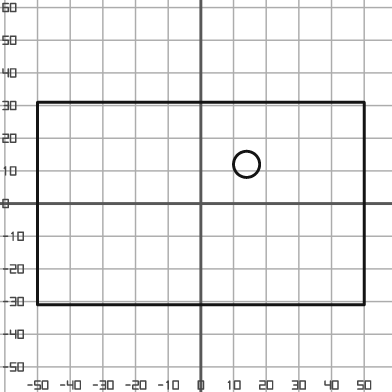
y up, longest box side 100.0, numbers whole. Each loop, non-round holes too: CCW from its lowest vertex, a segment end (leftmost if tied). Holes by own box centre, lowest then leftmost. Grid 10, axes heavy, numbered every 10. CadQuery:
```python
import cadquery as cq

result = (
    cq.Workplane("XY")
    .moveTo(-50.0, -31.0)
    .lineTo(50.0, -31.0)
    .lineTo(50.0, 31.0)
    .lineTo(-50.0, 31.0)
    .close()
    .moveTo(14.0, 12.0)
    .circle(4.0)
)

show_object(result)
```